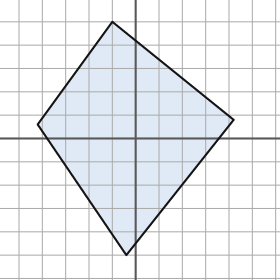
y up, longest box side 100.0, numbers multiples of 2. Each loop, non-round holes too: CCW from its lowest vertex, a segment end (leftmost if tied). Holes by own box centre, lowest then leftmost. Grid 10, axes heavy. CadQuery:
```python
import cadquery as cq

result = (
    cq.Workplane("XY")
    .moveTo(-4.0, -50.0)
    .lineTo(42.0, 8.0)
    .lineTo(-10.0, 50.0)
    .lineTo(-42.0, 6.0)
    .close()
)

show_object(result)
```